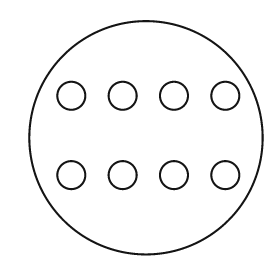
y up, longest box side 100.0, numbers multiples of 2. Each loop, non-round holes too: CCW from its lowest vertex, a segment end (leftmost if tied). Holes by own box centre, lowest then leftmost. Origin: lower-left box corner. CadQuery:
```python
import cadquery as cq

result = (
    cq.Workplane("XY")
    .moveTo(50.0, 50.0)
    .circle(50.0)
    .moveTo(18.0, 34.0)
    .circle(6.0)
    .moveTo(40.0, 34.0)
    .circle(6.0)
    .moveTo(62.0, 34.0)
    .circle(6.0)
    .moveTo(84.0, 34.0)
    .circle(6.0)
    .moveTo(18.0, 68.0)
    .circle(6.0)
    .moveTo(40.0, 68.0)
    .circle(6.0)
    .moveTo(62.0, 68.0)
    .circle(6.0)
    .moveTo(84.0, 68.0)
    .circle(6.0)
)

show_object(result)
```